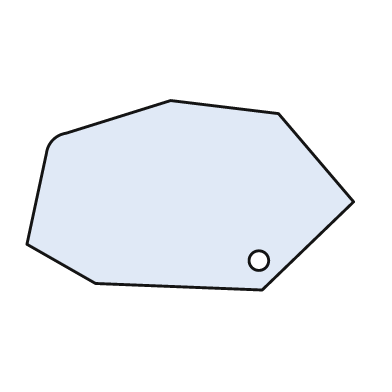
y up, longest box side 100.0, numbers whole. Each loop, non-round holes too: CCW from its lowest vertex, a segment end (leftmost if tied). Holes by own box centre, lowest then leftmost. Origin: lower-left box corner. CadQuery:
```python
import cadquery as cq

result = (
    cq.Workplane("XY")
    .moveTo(72.0, 0.0)
    .lineTo(100.0, 27.0)
    .lineTo(77.0, 54.0)
    .lineTo(44.0, 58.0)
    .lineTo(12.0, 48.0)
    .threePointArc((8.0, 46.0), (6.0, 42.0))
    .lineTo(0.0, 14.0)
    .lineTo(21.0, 2.0)
    .close()
    .moveTo(71.0, 9.0)
    .circle(3.0)
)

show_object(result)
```